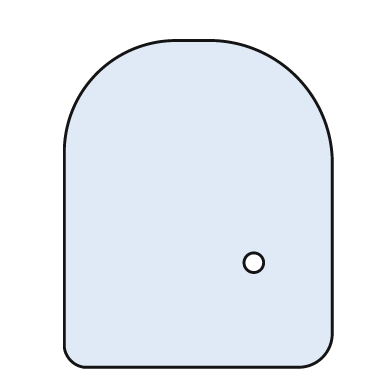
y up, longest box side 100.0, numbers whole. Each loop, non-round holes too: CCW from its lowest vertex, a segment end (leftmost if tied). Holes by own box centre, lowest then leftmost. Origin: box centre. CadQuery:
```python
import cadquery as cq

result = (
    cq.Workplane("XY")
    .moveTo(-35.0, -50.0)
    .lineTo(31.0, -50.0)
    .threePointArc((38.0, -47.0), (41.0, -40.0))
    .lineTo(41.0, 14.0)
    .threePointArc((30.0, 39.0), (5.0, 50.0))
    .lineTo(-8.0, 50.0)
    .threePointArc((-31.0, 40.0), (-41.0, 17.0))
    .lineTo(-41.0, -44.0)
    .threePointArc((-39.0, -48.0), (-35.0, -50.0))
    .close()
    .moveTo(17.0, -18.0)
    .circle(3.0)
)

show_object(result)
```